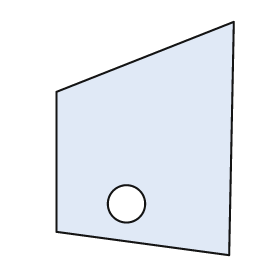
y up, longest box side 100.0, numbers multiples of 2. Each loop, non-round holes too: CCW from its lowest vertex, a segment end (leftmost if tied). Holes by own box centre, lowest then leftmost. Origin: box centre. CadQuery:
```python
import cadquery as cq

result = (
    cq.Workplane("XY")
    .moveTo(36.0, -50.0)
    .lineTo(38.0, 50.0)
    .lineTo(-38.0, 20.0)
    .lineTo(-38.0, -40.0)
    .close()
    .moveTo(-8.0, -28.0)
    .circle(8.0)
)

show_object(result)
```